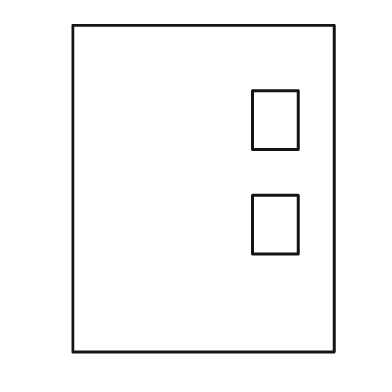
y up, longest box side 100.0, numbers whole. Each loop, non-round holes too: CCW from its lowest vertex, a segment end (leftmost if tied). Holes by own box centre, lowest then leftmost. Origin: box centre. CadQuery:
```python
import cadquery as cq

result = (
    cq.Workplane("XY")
    .moveTo(-40.0, -50.0)
    .lineTo(40.0, -50.0)
    .lineTo(40.0, 50.0)
    .lineTo(-40.0, 50.0)
    .close()
    .moveTo(15.0, -20.0)
    .lineTo(29.0, -20.0)
    .lineTo(29.0, -2.0)
    .lineTo(15.0, -2.0)
    .close()
    .moveTo(15.0, 12.0)
    .lineTo(29.0, 12.0)
    .lineTo(29.0, 30.0)
    .lineTo(15.0, 30.0)
    .close()
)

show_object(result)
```